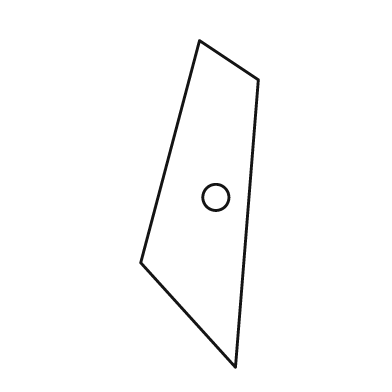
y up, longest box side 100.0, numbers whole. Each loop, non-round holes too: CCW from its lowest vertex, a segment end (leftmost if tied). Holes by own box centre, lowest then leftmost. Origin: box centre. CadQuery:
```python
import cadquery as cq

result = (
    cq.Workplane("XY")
    .moveTo(11.0, -50.0)
    .lineTo(18.0, 38.0)
    .lineTo(0.0, 50.0)
    .lineTo(-18.0, -18.0)
    .close()
    .moveTo(5.0, 2.0)
    .circle(4.0)
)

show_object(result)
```